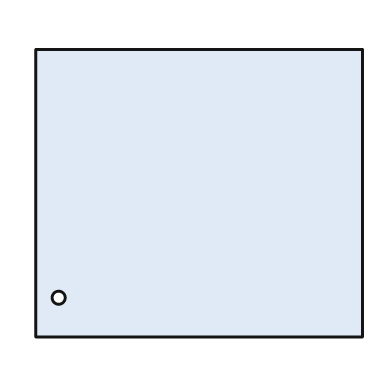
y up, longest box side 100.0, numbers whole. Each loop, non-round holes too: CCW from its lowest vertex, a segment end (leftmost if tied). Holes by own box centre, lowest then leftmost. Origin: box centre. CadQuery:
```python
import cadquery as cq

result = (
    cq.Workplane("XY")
    .moveTo(-50.0, -44.0)
    .lineTo(50.0, -44.0)
    .lineTo(50.0, 44.0)
    .lineTo(-50.0, 44.0)
    .close()
    .moveTo(-43.0, -32.0)
    .circle(2.0)
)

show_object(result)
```